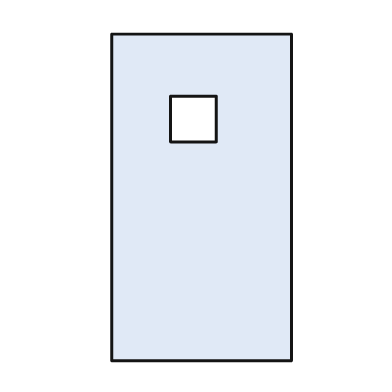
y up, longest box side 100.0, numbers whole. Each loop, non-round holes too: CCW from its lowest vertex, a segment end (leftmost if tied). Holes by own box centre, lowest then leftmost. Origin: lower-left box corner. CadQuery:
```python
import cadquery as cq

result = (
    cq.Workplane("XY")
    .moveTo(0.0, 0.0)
    .lineTo(55.0, 0.0)
    .lineTo(55.0, 100.0)
    .lineTo(0.0, 100.0)
    .close()
    .moveTo(18.0, 67.0)
    .lineTo(32.0, 67.0)
    .lineTo(32.0, 81.0)
    .lineTo(18.0, 81.0)
    .close()
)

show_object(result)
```